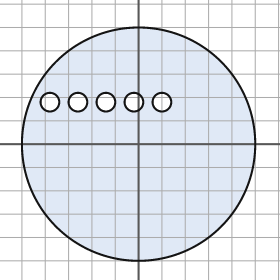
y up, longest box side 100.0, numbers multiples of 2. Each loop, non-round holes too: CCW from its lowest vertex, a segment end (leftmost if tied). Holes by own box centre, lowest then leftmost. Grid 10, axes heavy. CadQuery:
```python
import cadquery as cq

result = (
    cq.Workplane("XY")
    .moveTo(0.0, 0.0)
    .circle(50.0)
    .moveTo(-38.0, 18.0)
    .circle(4.0)
    .moveTo(-26.0, 18.0)
    .circle(4.0)
    .moveTo(-14.0, 18.0)
    .circle(4.0)
    .moveTo(-2.0, 18.0)
    .circle(4.0)
    .moveTo(10.0, 18.0)
    .circle(4.0)
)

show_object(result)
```